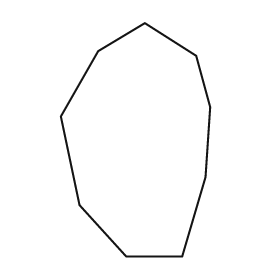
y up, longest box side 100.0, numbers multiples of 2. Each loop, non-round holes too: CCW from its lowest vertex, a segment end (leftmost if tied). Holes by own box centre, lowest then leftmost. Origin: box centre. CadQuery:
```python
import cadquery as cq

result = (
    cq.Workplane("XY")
    .moveTo(-4.0, -50.0)
    .lineTo(20.0, -50.0)
    .lineTo(30.0, -16.0)
    .lineTo(32.0, 14.0)
    .lineTo(26.0, 36.0)
    .lineTo(4.0, 50.0)
    .lineTo(-16.0, 38.0)
    .lineTo(-32.0, 10.0)
    .lineTo(-24.0, -28.0)
    .close()
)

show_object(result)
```